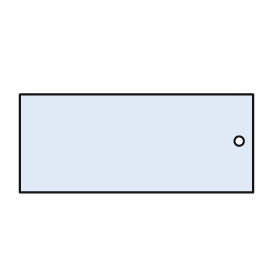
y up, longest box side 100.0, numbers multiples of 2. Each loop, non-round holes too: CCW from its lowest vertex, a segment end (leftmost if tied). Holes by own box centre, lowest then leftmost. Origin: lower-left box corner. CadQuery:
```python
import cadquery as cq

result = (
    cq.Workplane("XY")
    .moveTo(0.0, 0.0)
    .lineTo(100.0, 0.0)
    .lineTo(100.0, 42.0)
    .lineTo(0.0, 42.0)
    .close()
    .moveTo(94.0, 22.0)
    .circle(2.0)
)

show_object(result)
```